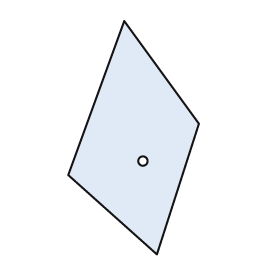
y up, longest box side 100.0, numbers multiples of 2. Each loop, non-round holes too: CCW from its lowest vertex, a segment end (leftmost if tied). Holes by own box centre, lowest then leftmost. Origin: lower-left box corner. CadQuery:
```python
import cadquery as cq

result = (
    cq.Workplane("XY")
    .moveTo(38.0, 0.0)
    .lineTo(56.0, 56.0)
    .lineTo(24.0, 100.0)
    .lineTo(0.0, 34.0)
    .close()
    .moveTo(32.0, 40.0)
    .circle(2.0)
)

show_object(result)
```